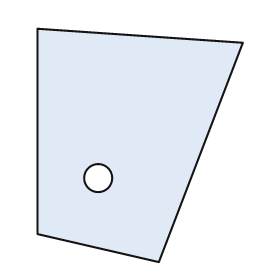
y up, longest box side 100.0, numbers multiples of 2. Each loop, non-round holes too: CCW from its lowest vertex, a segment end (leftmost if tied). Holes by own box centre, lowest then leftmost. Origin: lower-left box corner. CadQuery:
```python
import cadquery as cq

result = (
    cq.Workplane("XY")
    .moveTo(52.0, 0.0)
    .lineTo(88.0, 94.0)
    .lineTo(0.0, 100.0)
    .lineTo(0.0, 12.0)
    .close()
    .moveTo(26.0, 36.0)
    .circle(6.0)
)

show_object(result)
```